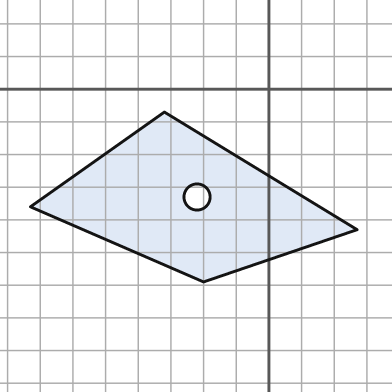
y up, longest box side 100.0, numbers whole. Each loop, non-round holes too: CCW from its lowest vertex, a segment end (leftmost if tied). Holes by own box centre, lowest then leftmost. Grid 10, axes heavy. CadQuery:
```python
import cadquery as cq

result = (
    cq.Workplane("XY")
    .moveTo(-20.0, -59.0)
    .lineTo(27.0, -43.0)
    .lineTo(-32.0, -7.0)
    .lineTo(-73.0, -36.0)
    .close()
    .moveTo(-22.0, -33.0)
    .circle(4.0)
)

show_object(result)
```